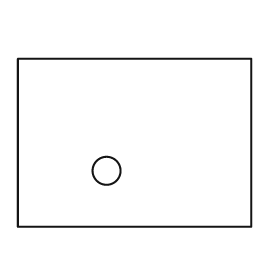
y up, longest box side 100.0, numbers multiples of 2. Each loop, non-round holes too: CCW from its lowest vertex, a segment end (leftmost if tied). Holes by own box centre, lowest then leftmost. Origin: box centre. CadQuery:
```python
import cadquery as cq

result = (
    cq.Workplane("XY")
    .moveTo(-50.0, -36.0)
    .lineTo(50.0, -36.0)
    .lineTo(50.0, 36.0)
    .lineTo(-50.0, 36.0)
    .close()
    .moveTo(-12.0, -12.0)
    .circle(6.0)
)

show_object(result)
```